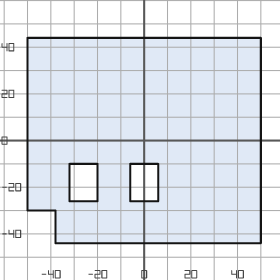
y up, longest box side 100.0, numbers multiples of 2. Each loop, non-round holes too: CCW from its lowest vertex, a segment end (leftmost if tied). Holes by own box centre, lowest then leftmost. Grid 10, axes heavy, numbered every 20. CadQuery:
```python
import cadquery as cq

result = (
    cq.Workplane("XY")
    .moveTo(-38.0, -44.0)
    .lineTo(50.0, -44.0)
    .lineTo(50.0, 44.0)
    .lineTo(-50.0, 44.0)
    .lineTo(-50.0, -30.0)
    .lineTo(-38.0, -30.0)
    .close()
    .moveTo(-32.0, -26.0)
    .lineTo(-20.0, -26.0)
    .lineTo(-20.0, -10.0)
    .lineTo(-32.0, -10.0)
    .close()
    .moveTo(-6.0, -26.0)
    .lineTo(6.0, -26.0)
    .lineTo(6.0, -10.0)
    .lineTo(-6.0, -10.0)
    .close()
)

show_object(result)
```